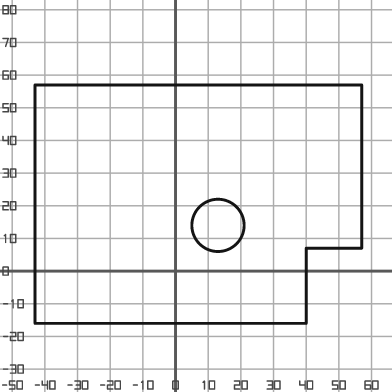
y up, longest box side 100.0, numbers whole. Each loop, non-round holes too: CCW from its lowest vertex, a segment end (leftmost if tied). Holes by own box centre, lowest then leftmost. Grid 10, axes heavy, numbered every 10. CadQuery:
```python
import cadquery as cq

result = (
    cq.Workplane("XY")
    .moveTo(-43.0, -16.0)
    .lineTo(40.0, -16.0)
    .lineTo(40.0, 7.0)
    .lineTo(57.0, 7.0)
    .lineTo(57.0, 57.0)
    .lineTo(-43.0, 57.0)
    .close()
    .moveTo(13.0, 14.0)
    .circle(8.0)
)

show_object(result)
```